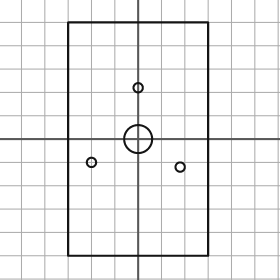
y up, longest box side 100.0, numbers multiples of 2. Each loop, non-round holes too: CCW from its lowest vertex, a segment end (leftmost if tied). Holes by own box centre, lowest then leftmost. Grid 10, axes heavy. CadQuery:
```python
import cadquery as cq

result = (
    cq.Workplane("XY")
    .moveTo(-30.0, -50.0)
    .lineTo(30.0, -50.0)
    .lineTo(30.0, 50.0)
    .lineTo(-30.0, 50.0)
    .close()
    .moveTo(18.0, -12.0)
    .circle(2.0)
    .moveTo(-20.0, -10.0)
    .circle(2.0)
    .moveTo(0.0, 0.0)
    .circle(6.0)
    .moveTo(0.0, 22.0)
    .circle(2.0)
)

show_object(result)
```